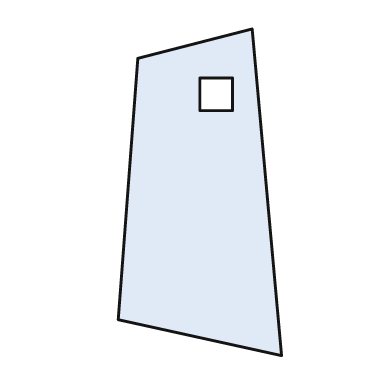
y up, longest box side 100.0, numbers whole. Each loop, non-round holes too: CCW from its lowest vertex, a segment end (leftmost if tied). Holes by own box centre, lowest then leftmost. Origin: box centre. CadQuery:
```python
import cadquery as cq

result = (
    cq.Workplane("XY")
    .moveTo(25.0, -50.0)
    .lineTo(16.0, 50.0)
    .lineTo(-19.0, 41.0)
    .lineTo(-25.0, -39.0)
    .close()
    .moveTo(0.0, 25.0)
    .lineTo(10.0, 25.0)
    .lineTo(10.0, 35.0)
    .lineTo(0.0, 35.0)
    .close()
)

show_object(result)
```